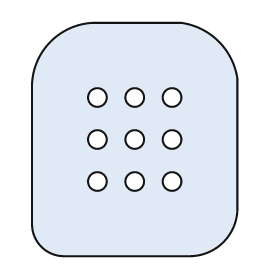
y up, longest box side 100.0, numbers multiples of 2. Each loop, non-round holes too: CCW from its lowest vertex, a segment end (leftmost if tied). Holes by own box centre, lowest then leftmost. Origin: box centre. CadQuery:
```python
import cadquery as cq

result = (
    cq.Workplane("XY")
    .moveTo(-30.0, -50.0)
    .lineTo(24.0, -50.0)
    .threePointArc((38.0, -44.0), (44.0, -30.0))
    .lineTo(44.0, 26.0)
    .threePointArc((36.0, 42.0), (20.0, 50.0))
    .lineTo(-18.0, 50.0)
    .threePointArc((-36.0, 42.0), (-44.0, 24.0))
    .lineTo(-44.0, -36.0)
    .threePointArc((-40.0, -46.0), (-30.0, -50.0))
    .close()
    .moveTo(-16.0, -18.0)
    .circle(4.0)
    .moveTo(0.0, -18.0)
    .circle(4.0)
    .moveTo(16.0, -18.0)
    .circle(4.0)
    .moveTo(-16.0, 0.0)
    .circle(4.0)
    .moveTo(0.0, 0.0)
    .circle(4.0)
    .moveTo(16.0, 0.0)
    .circle(4.0)
    .moveTo(-16.0, 18.0)
    .circle(4.0)
    .moveTo(0.0, 18.0)
    .circle(4.0)
    .moveTo(16.0, 18.0)
    .circle(4.0)
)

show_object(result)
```